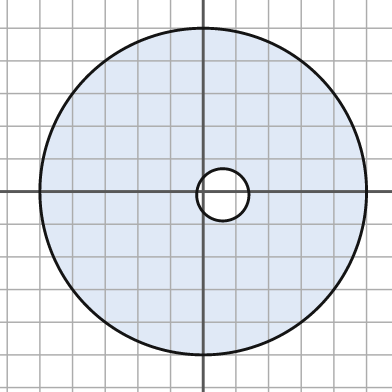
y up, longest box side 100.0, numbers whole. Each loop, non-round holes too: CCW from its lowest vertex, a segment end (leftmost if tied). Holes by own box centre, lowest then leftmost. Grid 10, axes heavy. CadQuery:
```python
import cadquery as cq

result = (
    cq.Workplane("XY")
    .moveTo(0.0, 0.0)
    .circle(50.0)
    .moveTo(6.0, -1.0)
    .circle(8.0)
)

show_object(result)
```